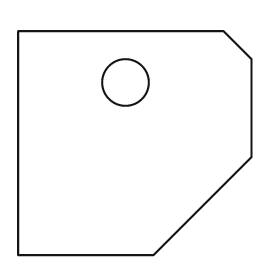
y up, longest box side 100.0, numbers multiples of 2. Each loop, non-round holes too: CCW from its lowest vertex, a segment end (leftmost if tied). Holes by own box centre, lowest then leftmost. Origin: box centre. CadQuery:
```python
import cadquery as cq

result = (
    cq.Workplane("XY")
    .moveTo(-50.0, -48.0)
    .lineTo(8.0, -48.0)
    .lineTo(50.0, -6.0)
    .lineTo(50.0, 36.0)
    .lineTo(38.0, 48.0)
    .lineTo(-50.0, 48.0)
    .close()
    .moveTo(-4.0, 26.0)
    .circle(10.0)
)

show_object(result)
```